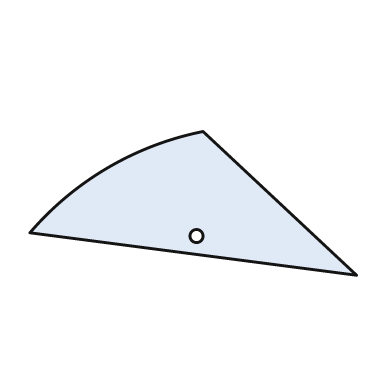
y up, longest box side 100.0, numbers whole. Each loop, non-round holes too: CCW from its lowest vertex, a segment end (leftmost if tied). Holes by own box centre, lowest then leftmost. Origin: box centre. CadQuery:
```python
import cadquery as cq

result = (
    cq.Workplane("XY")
    .moveTo(50.0, -22.0)
    .lineTo(3.0, 22.0)
    .threePointArc((-26.0, 11.0), (-50.0, -9.0))
    .close()
    .moveTo(1.0, -10.0)
    .circle(2.0)
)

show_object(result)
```